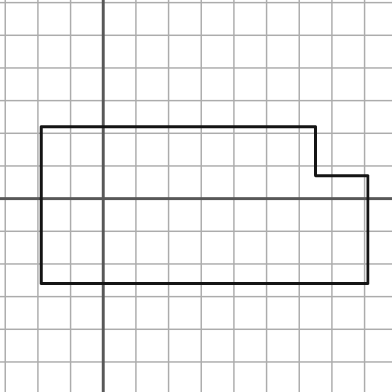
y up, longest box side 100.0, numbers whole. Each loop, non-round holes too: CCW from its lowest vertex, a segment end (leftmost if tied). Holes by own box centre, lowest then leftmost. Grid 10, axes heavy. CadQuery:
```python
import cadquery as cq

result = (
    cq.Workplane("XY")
    .moveTo(-19.0, -26.0)
    .lineTo(81.0, -26.0)
    .lineTo(81.0, 7.0)
    .lineTo(65.0, 7.0)
    .lineTo(65.0, 22.0)
    .lineTo(-19.0, 22.0)
    .close()
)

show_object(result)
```